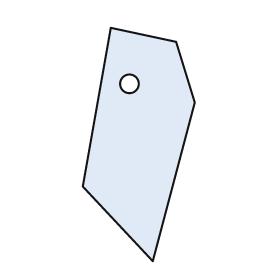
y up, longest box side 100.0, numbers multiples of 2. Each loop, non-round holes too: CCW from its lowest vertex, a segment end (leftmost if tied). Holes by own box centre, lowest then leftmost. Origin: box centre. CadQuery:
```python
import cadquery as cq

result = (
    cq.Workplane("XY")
    .moveTo(6.0, -50.0)
    .lineTo(24.0, 18.0)
    .lineTo(16.0, 44.0)
    .lineTo(-12.0, 50.0)
    .lineTo(-24.0, -18.0)
    .close()
    .moveTo(-4.0, 26.0)
    .circle(4.0)
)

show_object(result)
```